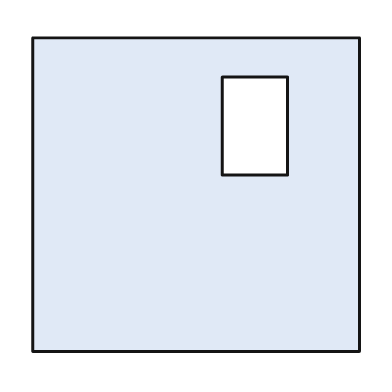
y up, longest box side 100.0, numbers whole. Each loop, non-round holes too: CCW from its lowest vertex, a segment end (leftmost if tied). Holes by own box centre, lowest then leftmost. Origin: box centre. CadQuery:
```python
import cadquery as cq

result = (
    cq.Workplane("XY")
    .moveTo(-50.0, -48.0)
    .lineTo(50.0, -48.0)
    .lineTo(50.0, 48.0)
    .lineTo(-50.0, 48.0)
    .close()
    .moveTo(8.0, 6.0)
    .lineTo(28.0, 6.0)
    .lineTo(28.0, 36.0)
    .lineTo(8.0, 36.0)
    .close()
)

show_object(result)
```